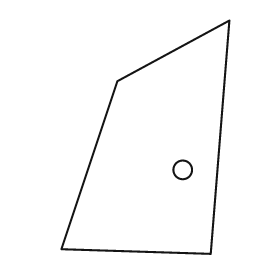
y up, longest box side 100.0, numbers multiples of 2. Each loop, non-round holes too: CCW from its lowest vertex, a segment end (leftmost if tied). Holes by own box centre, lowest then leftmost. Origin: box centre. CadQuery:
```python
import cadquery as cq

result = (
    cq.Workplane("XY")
    .moveTo(28.0, -50.0)
    .lineTo(36.0, 50.0)
    .lineTo(-12.0, 24.0)
    .lineTo(-36.0, -48.0)
    .close()
    .moveTo(16.0, -14.0)
    .circle(4.0)
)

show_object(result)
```